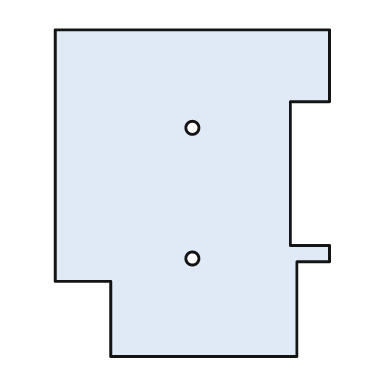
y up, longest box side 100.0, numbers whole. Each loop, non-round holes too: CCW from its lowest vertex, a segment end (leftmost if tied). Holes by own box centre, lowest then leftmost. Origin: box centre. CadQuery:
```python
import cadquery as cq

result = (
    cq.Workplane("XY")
    .moveTo(-25.0, -50.0)
    .lineTo(32.0, -50.0)
    .lineTo(32.0, -21.0)
    .lineTo(42.0, -21.0)
    .lineTo(42.0, -16.0)
    .lineTo(30.0, -16.0)
    .lineTo(30.0, 28.0)
    .lineTo(42.0, 28.0)
    .lineTo(42.0, 50.0)
    .lineTo(-42.0, 50.0)
    .lineTo(-42.0, -27.0)
    .lineTo(-25.0, -27.0)
    .close()
    .moveTo(0.0, -20.0)
    .circle(2.0)
    .moveTo(0.0, 20.0)
    .circle(2.0)
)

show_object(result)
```